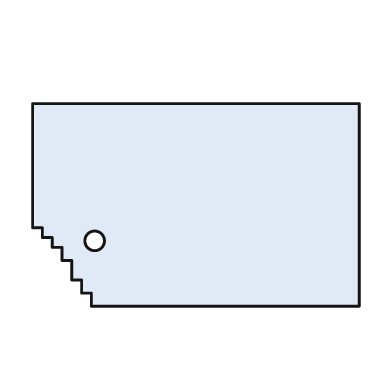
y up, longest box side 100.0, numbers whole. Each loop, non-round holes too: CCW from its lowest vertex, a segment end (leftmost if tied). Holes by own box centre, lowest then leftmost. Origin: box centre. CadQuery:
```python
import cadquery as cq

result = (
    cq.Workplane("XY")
    .moveTo(-32.0, -31.0)
    .lineTo(50.0, -31.0)
    .lineTo(50.0, 31.0)
    .lineTo(-50.0, 31.0)
    .lineTo(-50.0, -7.0)
    .lineTo(-47.0, -7.0)
    .lineTo(-47.0, -10.0)
    .lineTo(-44.0, -10.0)
    .lineTo(-44.0, -13.0)
    .lineTo(-41.0, -13.0)
    .lineTo(-41.0, -17.0)
    .lineTo(-38.0, -17.0)
    .lineTo(-38.0, -23.0)
    .lineTo(-35.0, -23.0)
    .lineTo(-35.0, -27.0)
    .lineTo(-32.0, -27.0)
    .close()
    .moveTo(-31.0, -11.0)
    .circle(3.0)
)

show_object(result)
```